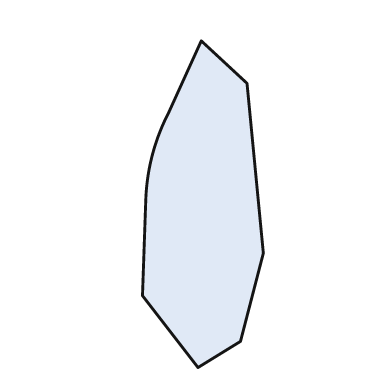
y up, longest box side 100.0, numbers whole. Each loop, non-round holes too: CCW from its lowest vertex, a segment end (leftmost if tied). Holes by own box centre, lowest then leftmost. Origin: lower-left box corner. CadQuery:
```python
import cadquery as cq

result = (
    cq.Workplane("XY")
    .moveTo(17.0, 0.0)
    .lineTo(30.0, 8.0)
    .lineTo(37.0, 35.0)
    .lineTo(32.0, 87.0)
    .lineTo(18.0, 100.0)
    .lineTo(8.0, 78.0)
    .threePointArc((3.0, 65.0), (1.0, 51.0))
    .lineTo(0.0, 22.0)
    .close()
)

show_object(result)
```